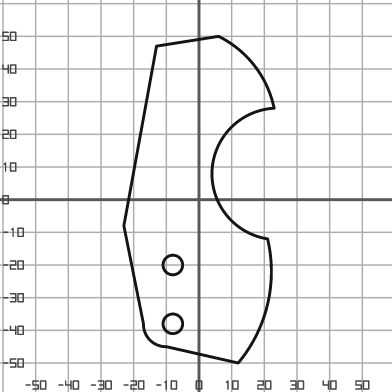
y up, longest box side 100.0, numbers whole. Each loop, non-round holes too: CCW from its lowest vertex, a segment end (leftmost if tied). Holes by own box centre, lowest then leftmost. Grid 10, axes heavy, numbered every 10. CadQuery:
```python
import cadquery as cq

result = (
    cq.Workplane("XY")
    .moveTo(12.0, -50.0)
    .threePointArc((21.0, -32.0), (21.0, -12.0))
    .threePointArc((4.0, 9.0), (23.0, 28.0))
    .threePointArc((17.0, 41.0), (6.0, 50.0))
    .lineTo(-13.0, 47.0)
    .lineTo(-23.0, -8.0)
    .lineTo(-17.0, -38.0)
    .threePointArc((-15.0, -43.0), (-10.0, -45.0))
    .close()
    .moveTo(-8.0, -38.0)
    .circle(3.0)
    .moveTo(-8.0, -20.0)
    .circle(3.0)
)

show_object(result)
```